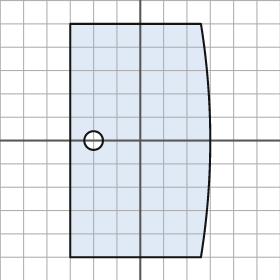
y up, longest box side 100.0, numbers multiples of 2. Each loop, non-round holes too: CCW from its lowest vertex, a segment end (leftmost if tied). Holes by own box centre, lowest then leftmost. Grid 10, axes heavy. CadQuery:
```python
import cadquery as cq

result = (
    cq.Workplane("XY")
    .moveTo(-30.0, -50.0)
    .lineTo(26.0, -50.0)
    .threePointArc((30.0, 0.0), (26.0, 50.0))
    .lineTo(-30.0, 50.0)
    .close()
    .moveTo(-20.0, 0.0)
    .circle(4.0)
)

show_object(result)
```